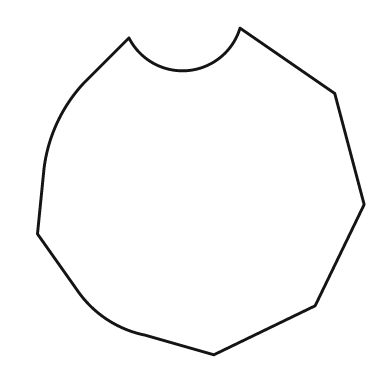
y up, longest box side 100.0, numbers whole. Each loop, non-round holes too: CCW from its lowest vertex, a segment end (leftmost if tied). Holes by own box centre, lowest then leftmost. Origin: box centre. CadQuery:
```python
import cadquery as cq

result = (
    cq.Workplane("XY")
    .moveTo(4.0, -50.0)
    .lineTo(35.0, -35.0)
    .lineTo(50.0, -4.0)
    .lineTo(41.0, 30.0)
    .lineTo(12.0, 50.0)
    .threePointArc((-4.0, 37.0), (-22.0, 47.0))
    .lineTo(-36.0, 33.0)
    .threePointArc((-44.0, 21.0), (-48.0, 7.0))
    .lineTo(-50.0, -13.0)
    .lineTo(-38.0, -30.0)
    .threePointArc((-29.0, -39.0), (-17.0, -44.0))
    .close()
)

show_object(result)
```